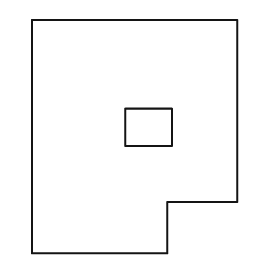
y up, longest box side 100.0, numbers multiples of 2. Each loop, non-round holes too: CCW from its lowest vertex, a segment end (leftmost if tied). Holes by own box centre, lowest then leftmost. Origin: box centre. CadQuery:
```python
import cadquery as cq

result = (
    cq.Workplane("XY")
    .moveTo(-44.0, -50.0)
    .lineTo(14.0, -50.0)
    .lineTo(14.0, -28.0)
    .lineTo(44.0, -28.0)
    .lineTo(44.0, 50.0)
    .lineTo(-44.0, 50.0)
    .close()
    .moveTo(-4.0, -4.0)
    .lineTo(16.0, -4.0)
    .lineTo(16.0, 12.0)
    .lineTo(-4.0, 12.0)
    .close()
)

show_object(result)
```